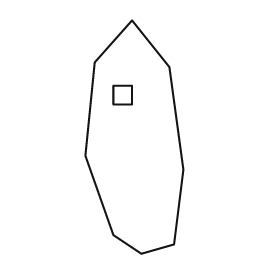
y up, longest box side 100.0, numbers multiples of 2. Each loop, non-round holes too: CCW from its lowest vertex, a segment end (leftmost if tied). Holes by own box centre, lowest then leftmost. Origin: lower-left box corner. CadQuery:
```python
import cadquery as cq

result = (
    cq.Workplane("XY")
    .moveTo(24.0, 0.0)
    .lineTo(38.0, 4.0)
    .lineTo(42.0, 36.0)
    .lineTo(36.0, 80.0)
    .lineTo(20.0, 100.0)
    .lineTo(4.0, 82.0)
    .lineTo(0.0, 42.0)
    .lineTo(12.0, 8.0)
    .close()
    .moveTo(12.0, 64.0)
    .lineTo(20.0, 64.0)
    .lineTo(20.0, 72.0)
    .lineTo(12.0, 72.0)
    .close()
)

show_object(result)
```